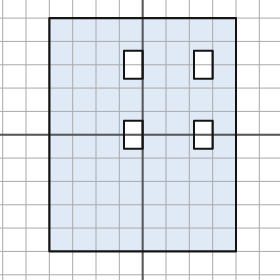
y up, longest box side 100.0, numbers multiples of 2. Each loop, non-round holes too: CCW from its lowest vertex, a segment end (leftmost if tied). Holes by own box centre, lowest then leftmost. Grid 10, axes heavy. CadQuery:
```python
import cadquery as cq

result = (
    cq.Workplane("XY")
    .moveTo(-40.0, -50.0)
    .lineTo(40.0, -50.0)
    .lineTo(40.0, 50.0)
    .lineTo(-40.0, 50.0)
    .close()
    .moveTo(-8.0, -6.0)
    .lineTo(0.0, -6.0)
    .lineTo(0.0, 6.0)
    .lineTo(-8.0, 6.0)
    .close()
    .moveTo(22.0, -6.0)
    .lineTo(30.0, -6.0)
    .lineTo(30.0, 6.0)
    .lineTo(22.0, 6.0)
    .close()
    .moveTo(-8.0, 24.0)
    .lineTo(0.0, 24.0)
    .lineTo(0.0, 36.0)
    .lineTo(-8.0, 36.0)
    .close()
    .moveTo(22.0, 24.0)
    .lineTo(30.0, 24.0)
    .lineTo(30.0, 36.0)
    .lineTo(22.0, 36.0)
    .close()
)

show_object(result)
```